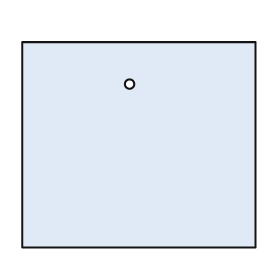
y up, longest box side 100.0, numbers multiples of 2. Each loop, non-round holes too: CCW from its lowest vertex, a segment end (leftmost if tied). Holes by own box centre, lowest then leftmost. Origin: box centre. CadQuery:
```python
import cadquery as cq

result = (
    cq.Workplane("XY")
    .moveTo(-50.0, -44.0)
    .lineTo(50.0, -44.0)
    .lineTo(50.0, 44.0)
    .lineTo(-50.0, 44.0)
    .close()
    .moveTo(-4.0, 26.0)
    .circle(2.0)
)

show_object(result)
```